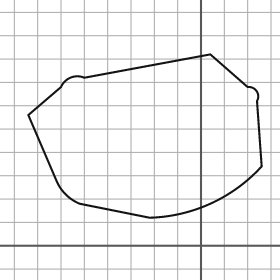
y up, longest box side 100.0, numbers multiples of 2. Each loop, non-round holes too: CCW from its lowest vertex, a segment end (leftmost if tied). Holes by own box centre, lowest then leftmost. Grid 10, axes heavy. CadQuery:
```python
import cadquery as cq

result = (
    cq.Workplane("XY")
    .moveTo(-22.0, 12.0)
    .threePointArc((4.0, 18.0), (26.0, 34.0))
    .lineTo(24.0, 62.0)
    .threePointArc((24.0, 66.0), (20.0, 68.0))
    .lineTo(4.0, 82.0)
    .lineTo(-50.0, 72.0)
    .threePointArc((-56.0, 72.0), (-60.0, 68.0))
    .lineTo(-74.0, 56.0)
    .lineTo(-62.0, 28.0)
    .threePointArc((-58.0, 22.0), (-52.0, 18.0))
    .close()
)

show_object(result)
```